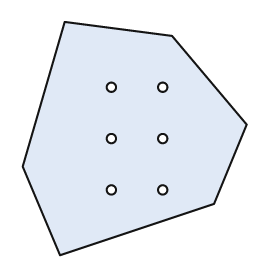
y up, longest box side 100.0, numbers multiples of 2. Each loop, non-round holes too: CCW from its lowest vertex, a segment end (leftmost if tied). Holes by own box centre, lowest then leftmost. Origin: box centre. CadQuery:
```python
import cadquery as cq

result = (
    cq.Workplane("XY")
    .moveTo(-32.0, -50.0)
    .lineTo(34.0, -28.0)
    .lineTo(48.0, 6.0)
    .lineTo(16.0, 44.0)
    .lineTo(-30.0, 50.0)
    .lineTo(-48.0, -12.0)
    .close()
    .moveTo(-10.0, -22.0)
    .circle(2.0)
    .moveTo(12.0, -22.0)
    .circle(2.0)
    .moveTo(-10.0, 0.0)
    .circle(2.0)
    .moveTo(12.0, 0.0)
    .circle(2.0)
    .moveTo(-10.0, 22.0)
    .circle(2.0)
    .moveTo(12.0, 22.0)
    .circle(2.0)
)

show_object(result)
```